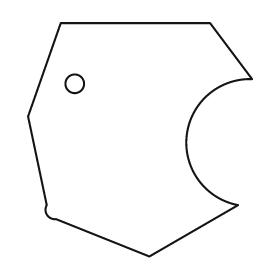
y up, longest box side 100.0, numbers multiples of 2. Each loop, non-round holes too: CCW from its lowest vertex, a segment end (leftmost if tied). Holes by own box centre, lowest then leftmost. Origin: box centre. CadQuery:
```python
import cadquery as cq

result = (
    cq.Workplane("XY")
    .moveTo(4.0, -50.0)
    .lineTo(42.0, -28.0)
    .threePointArc((20.0, 2.0), (48.0, 26.0))
    .lineTo(30.0, 50.0)
    .lineTo(-34.0, 50.0)
    .lineTo(-48.0, 10.0)
    .lineTo(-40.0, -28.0)
    .threePointArc((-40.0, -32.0), (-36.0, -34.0))
    .close()
    .moveTo(-28.0, 24.0)
    .circle(4.0)
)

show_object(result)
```